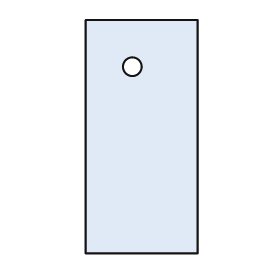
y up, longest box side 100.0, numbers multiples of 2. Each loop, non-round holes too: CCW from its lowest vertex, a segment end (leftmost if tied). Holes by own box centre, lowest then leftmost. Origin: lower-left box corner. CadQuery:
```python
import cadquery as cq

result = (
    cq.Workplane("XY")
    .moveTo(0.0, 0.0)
    .lineTo(48.0, 0.0)
    .lineTo(48.0, 100.0)
    .lineTo(0.0, 100.0)
    .close()
    .moveTo(20.0, 80.0)
    .circle(4.0)
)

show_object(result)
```